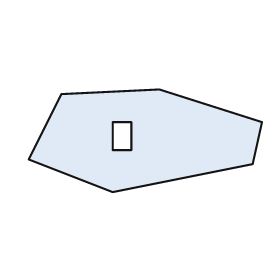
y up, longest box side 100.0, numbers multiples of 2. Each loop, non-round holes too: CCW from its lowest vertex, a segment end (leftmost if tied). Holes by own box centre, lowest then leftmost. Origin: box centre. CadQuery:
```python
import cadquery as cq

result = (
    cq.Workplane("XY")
    .moveTo(-14.0, -22.0)
    .lineTo(46.0, -10.0)
    .lineTo(50.0, 8.0)
    .lineTo(6.0, 22.0)
    .lineTo(-36.0, 20.0)
    .lineTo(-50.0, -8.0)
    .close()
    .moveTo(-14.0, -4.0)
    .lineTo(-6.0, -4.0)
    .lineTo(-6.0, 8.0)
    .lineTo(-14.0, 8.0)
    .close()
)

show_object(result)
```